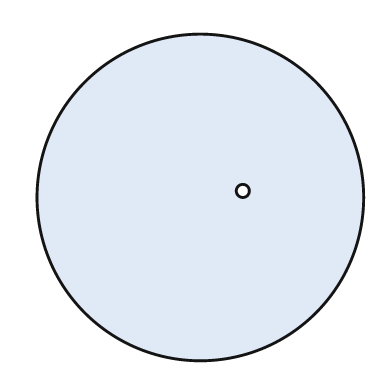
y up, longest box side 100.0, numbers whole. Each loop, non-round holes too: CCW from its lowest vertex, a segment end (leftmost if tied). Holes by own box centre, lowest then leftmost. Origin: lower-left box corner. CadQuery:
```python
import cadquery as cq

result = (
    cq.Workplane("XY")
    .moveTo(50.0, 50.0)
    .circle(50.0)
    .moveTo(63.0, 52.0)
    .circle(2.0)
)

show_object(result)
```